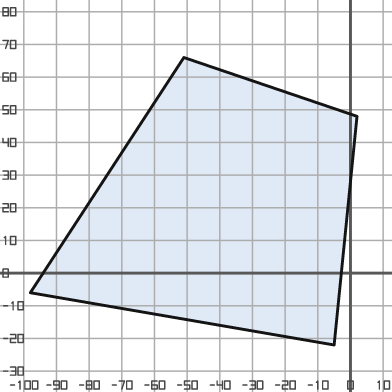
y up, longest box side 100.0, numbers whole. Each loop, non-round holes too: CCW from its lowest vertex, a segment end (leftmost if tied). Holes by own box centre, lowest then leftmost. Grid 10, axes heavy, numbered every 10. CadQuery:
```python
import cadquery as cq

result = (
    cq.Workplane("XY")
    .moveTo(-5.0, -22.0)
    .lineTo(2.0, 48.0)
    .lineTo(-51.0, 66.0)
    .lineTo(-98.0, -6.0)
    .close()
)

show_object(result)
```